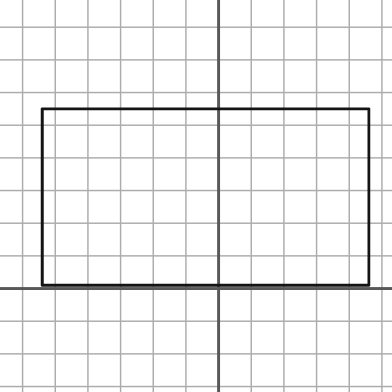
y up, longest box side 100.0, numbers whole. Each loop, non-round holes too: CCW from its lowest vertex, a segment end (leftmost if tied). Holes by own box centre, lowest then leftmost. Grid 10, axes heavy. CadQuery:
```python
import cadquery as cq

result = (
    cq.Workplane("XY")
    .moveTo(-54.0, 1.0)
    .lineTo(46.0, 1.0)
    .lineTo(46.0, 55.0)
    .lineTo(-54.0, 55.0)
    .close()
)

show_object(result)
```